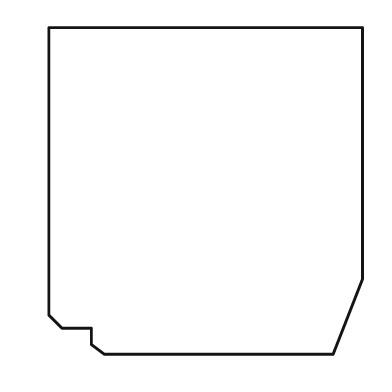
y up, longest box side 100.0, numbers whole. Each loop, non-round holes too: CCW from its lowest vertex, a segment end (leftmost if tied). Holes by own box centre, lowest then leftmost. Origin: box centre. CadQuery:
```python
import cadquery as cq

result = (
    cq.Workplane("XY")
    .moveTo(-31.0, -50.0)
    .lineTo(39.0, -50.0)
    .lineTo(48.0, -27.0)
    .lineTo(48.0, 50.0)
    .lineTo(-48.0, 50.0)
    .lineTo(-48.0, -38.0)
    .lineTo(-44.0, -42.0)
    .lineTo(-35.0, -42.0)
    .lineTo(-35.0, -47.0)
    .close()
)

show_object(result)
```